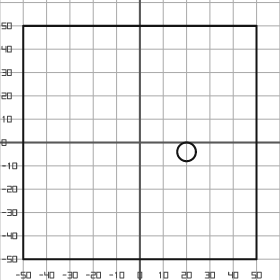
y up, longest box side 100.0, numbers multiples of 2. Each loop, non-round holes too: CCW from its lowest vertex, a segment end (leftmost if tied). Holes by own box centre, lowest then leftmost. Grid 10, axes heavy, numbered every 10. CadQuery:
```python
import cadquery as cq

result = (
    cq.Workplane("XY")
    .moveTo(-50.0, -50.0)
    .lineTo(50.0, -50.0)
    .lineTo(50.0, 50.0)
    .lineTo(-50.0, 50.0)
    .close()
    .moveTo(20.0, -4.0)
    .circle(4.0)
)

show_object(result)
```